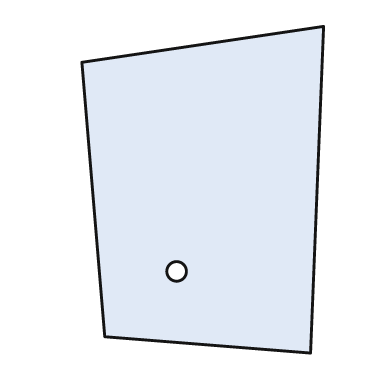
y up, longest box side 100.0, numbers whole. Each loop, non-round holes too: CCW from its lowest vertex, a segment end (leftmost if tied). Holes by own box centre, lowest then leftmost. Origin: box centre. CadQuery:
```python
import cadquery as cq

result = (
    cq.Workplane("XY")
    .moveTo(33.0, -50.0)
    .lineTo(37.0, 50.0)
    .lineTo(-37.0, 39.0)
    .lineTo(-30.0, -45.0)
    .close()
    .moveTo(-8.0, -25.0)
    .circle(3.0)
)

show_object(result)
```